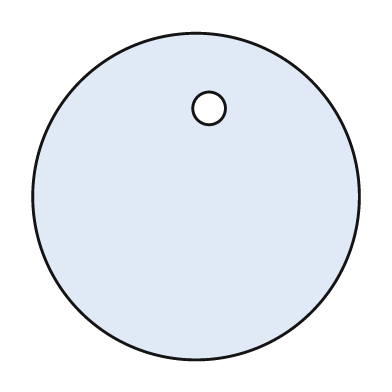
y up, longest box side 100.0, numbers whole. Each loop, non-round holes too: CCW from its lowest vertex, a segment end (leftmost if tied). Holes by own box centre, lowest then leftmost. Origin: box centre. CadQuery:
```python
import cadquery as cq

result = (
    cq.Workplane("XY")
    .moveTo(0.0, 0.0)
    .circle(50.0)
    .moveTo(4.0, 27.0)
    .circle(5.0)
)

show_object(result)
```